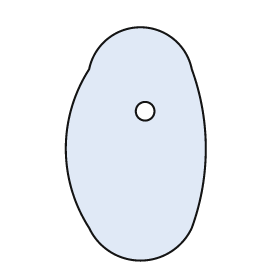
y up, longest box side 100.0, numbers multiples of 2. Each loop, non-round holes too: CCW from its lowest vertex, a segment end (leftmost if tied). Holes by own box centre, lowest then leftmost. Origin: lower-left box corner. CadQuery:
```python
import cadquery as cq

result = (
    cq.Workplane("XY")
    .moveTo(10.0, 14.0)
    .threePointArc((32.0, 0.0), (54.0, 14.0))
    .threePointArc((60.0, 48.0), (54.0, 82.0))
    .threePointArc((32.0, 100.0), (10.0, 82.0))
    .threePointArc((0.0, 48.0), (10.0, 14.0))
    .close()
    .moveTo(34.0, 64.0)
    .circle(4.0)
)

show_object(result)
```